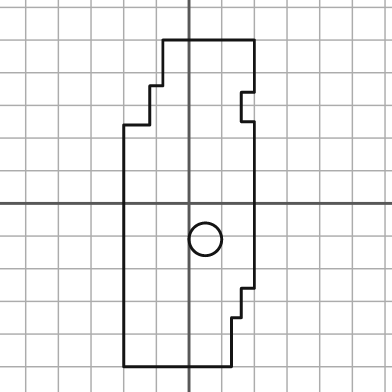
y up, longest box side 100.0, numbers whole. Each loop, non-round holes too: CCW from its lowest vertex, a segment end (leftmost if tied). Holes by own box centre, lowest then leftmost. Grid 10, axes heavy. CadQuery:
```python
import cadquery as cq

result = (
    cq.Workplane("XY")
    .moveTo(-20.0, -50.0)
    .lineTo(13.0, -50.0)
    .lineTo(13.0, -35.0)
    .lineTo(16.0, -35.0)
    .lineTo(16.0, -26.0)
    .lineTo(20.0, -26.0)
    .lineTo(20.0, 25.0)
    .lineTo(16.0, 25.0)
    .lineTo(16.0, 34.0)
    .lineTo(20.0, 34.0)
    .lineTo(20.0, 50.0)
    .lineTo(-8.0, 50.0)
    .lineTo(-8.0, 36.0)
    .lineTo(-12.0, 36.0)
    .lineTo(-12.0, 24.0)
    .lineTo(-20.0, 24.0)
    .close()
    .moveTo(5.0, -11.0)
    .circle(5.0)
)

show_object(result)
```